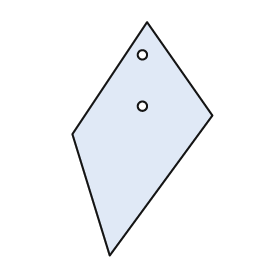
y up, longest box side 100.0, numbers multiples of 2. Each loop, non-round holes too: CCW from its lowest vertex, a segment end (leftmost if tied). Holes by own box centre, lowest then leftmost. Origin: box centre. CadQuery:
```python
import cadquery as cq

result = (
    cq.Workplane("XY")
    .moveTo(-14.0, -50.0)
    .lineTo(30.0, 10.0)
    .lineTo(2.0, 50.0)
    .lineTo(-30.0, 2.0)
    .close()
    .moveTo(0.0, 14.0)
    .circle(2.0)
    .moveTo(0.0, 36.0)
    .circle(2.0)
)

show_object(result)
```